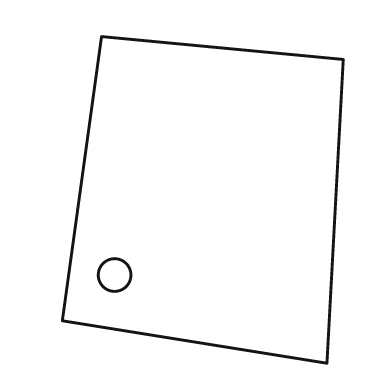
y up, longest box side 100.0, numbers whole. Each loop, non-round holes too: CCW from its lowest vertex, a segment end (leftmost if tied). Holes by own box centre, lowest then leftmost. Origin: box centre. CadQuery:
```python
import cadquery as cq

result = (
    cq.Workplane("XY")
    .moveTo(38.0, -50.0)
    .lineTo(43.0, 43.0)
    .lineTo(-31.0, 50.0)
    .lineTo(-43.0, -37.0)
    .close()
    .moveTo(-27.0, -23.0)
    .circle(5.0)
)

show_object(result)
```